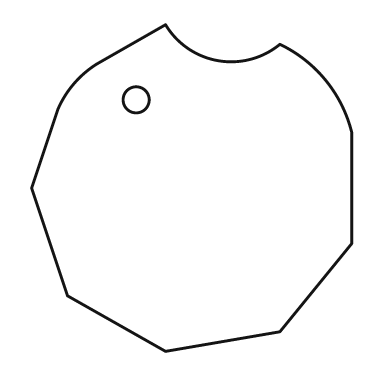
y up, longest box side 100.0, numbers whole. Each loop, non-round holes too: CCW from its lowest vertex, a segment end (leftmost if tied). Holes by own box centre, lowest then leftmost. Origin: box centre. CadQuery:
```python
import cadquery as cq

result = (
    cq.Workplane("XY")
    .moveTo(-8.0, -50.0)
    .lineTo(27.0, -44.0)
    .lineTo(49.0, -17.0)
    .lineTo(49.0, 17.0)
    .threePointArc((41.0, 33.0), (27.0, 44.0))
    .threePointArc((8.0, 39.0), (-8.0, 50.0))
    .lineTo(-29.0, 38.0)
    .threePointArc((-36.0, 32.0), (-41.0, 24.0))
    .lineTo(-49.0, 0.0)
    .lineTo(-38.0, -33.0)
    .close()
    .moveTo(-17.0, 27.0)
    .circle(4.0)
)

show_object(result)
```